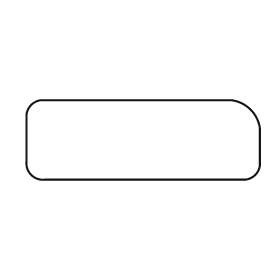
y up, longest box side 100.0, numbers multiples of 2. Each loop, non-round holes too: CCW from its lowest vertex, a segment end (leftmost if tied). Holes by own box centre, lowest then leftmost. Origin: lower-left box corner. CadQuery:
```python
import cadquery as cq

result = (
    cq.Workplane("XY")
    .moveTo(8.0, 0.0)
    .lineTo(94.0, 0.0)
    .threePointArc((98.0, 2.0), (100.0, 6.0))
    .lineTo(100.0, 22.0)
    .threePointArc((96.0, 30.0), (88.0, 34.0))
    .lineTo(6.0, 34.0)
    .threePointArc((2.0, 32.0), (0.0, 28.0))
    .lineTo(0.0, 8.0)
    .threePointArc((2.0, 2.0), (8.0, 0.0))
    .close()
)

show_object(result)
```